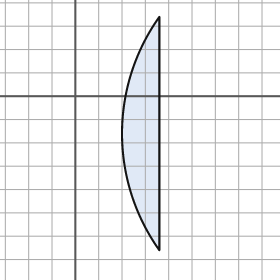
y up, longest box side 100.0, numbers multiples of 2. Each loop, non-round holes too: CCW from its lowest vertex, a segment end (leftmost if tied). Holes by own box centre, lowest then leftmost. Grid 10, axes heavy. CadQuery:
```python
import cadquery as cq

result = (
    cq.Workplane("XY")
    .moveTo(36.0, -66.0)
    .lineTo(36.0, 34.0)
    .threePointArc((20.0, -16.0), (36.0, -66.0))
    .close()
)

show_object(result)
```